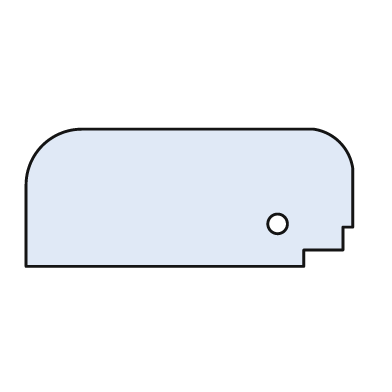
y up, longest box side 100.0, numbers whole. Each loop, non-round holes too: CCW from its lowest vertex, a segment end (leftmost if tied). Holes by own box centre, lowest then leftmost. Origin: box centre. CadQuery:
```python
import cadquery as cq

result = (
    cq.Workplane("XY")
    .moveTo(-50.0, -21.0)
    .lineTo(35.0, -21.0)
    .lineTo(35.0, -16.0)
    .lineTo(47.0, -16.0)
    .lineTo(47.0, -9.0)
    .lineTo(50.0, -9.0)
    .lineTo(50.0, 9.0)
    .threePointArc((46.0, 17.0), (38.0, 21.0))
    .lineTo(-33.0, 21.0)
    .threePointArc((-45.0, 16.0), (-50.0, 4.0))
    .close()
    .moveTo(27.0, -8.0)
    .circle(3.0)
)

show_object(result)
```